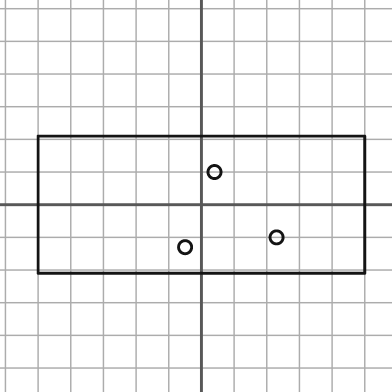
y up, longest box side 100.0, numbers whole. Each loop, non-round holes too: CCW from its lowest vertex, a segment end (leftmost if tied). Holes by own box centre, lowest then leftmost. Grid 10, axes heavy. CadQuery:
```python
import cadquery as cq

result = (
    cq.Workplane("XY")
    .moveTo(-50.0, -21.0)
    .lineTo(50.0, -21.0)
    .lineTo(50.0, 21.0)
    .lineTo(-50.0, 21.0)
    .close()
    .moveTo(-5.0, -13.0)
    .circle(2.0)
    .moveTo(23.0, -10.0)
    .circle(2.0)
    .moveTo(4.0, 10.0)
    .circle(2.0)
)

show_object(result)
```